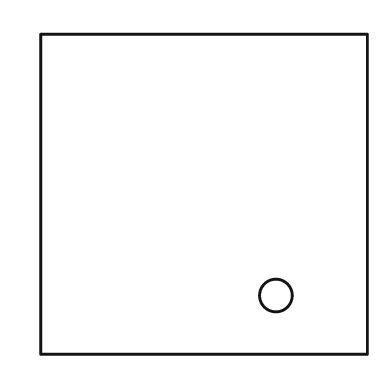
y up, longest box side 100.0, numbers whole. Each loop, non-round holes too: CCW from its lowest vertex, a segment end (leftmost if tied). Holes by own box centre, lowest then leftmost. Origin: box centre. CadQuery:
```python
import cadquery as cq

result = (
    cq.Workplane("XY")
    .moveTo(-50.0, -49.0)
    .lineTo(50.0, -49.0)
    .lineTo(50.0, 49.0)
    .lineTo(-50.0, 49.0)
    .close()
    .moveTo(22.0, -31.0)
    .circle(5.0)
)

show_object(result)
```